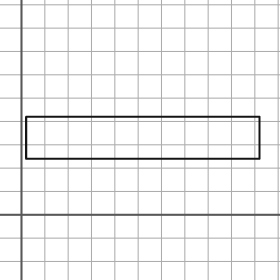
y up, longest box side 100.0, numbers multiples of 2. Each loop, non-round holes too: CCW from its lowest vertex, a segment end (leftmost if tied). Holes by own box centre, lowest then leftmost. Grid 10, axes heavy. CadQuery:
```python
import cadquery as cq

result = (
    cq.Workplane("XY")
    .moveTo(2.0, 24.0)
    .lineTo(102.0, 24.0)
    .lineTo(102.0, 42.0)
    .lineTo(2.0, 42.0)
    .close()
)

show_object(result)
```